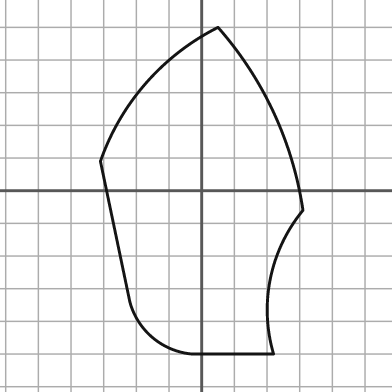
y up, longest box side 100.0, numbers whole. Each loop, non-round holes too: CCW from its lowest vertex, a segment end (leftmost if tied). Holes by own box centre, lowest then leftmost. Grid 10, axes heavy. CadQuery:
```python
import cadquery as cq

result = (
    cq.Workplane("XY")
    .moveTo(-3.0, -50.0)
    .lineTo(22.0, -50.0)
    .threePointArc((21.0, -27.0), (31.0, -6.0))
    .threePointArc((22.0, 24.0), (5.0, 50.0))
    .threePointArc((-17.0, 33.0), (-31.0, 9.0))
    .lineTo(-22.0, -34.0)
    .threePointArc((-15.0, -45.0), (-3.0, -50.0))
    .close()
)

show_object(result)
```